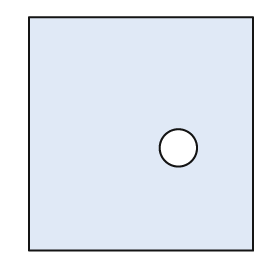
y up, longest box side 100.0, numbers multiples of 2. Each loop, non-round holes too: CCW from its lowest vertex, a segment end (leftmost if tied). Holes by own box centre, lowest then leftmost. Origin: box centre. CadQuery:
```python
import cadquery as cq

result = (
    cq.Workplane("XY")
    .moveTo(-48.0, -50.0)
    .lineTo(48.0, -50.0)
    .lineTo(48.0, 50.0)
    .lineTo(-48.0, 50.0)
    .close()
    .moveTo(16.0, -6.0)
    .circle(8.0)
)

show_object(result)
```